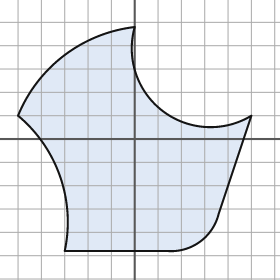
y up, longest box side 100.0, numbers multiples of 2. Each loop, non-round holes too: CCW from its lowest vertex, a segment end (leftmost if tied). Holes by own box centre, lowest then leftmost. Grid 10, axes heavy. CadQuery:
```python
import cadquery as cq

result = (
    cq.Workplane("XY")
    .moveTo(-30.0, -48.0)
    .lineTo(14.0, -48.0)
    .threePointArc((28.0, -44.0), (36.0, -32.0))
    .lineTo(50.0, 10.0)
    .threePointArc((12.0, 12.0), (0.0, 48.0))
    .threePointArc((-30.0, 36.0), (-50.0, 10.0))
    .threePointArc((-32.0, -16.0), (-30.0, -48.0))
    .close()
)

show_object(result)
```